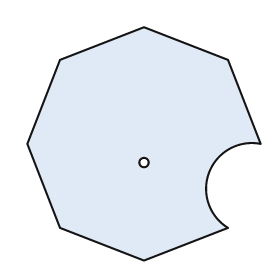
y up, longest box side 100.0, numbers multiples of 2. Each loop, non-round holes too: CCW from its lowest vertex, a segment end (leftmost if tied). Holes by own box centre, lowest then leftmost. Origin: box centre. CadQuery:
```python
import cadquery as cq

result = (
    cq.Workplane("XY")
    .moveTo(0.0, -50.0)
    .lineTo(36.0, -36.0)
    .threePointArc((28.0, -12.0), (50.0, 0.0))
    .lineTo(36.0, 36.0)
    .lineTo(0.0, 50.0)
    .lineTo(-36.0, 36.0)
    .lineTo(-50.0, 0.0)
    .lineTo(-36.0, -36.0)
    .close()
    .moveTo(0.0, -8.0)
    .circle(2.0)
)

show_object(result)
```